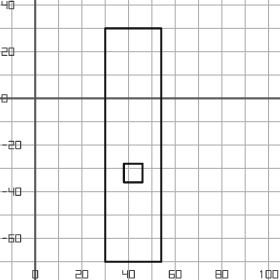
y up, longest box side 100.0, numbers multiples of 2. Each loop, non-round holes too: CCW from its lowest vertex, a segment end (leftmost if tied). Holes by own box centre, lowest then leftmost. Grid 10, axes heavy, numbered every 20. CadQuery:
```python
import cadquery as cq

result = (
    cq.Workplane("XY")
    .moveTo(30.0, -70.0)
    .lineTo(54.0, -70.0)
    .lineTo(54.0, 30.0)
    .lineTo(30.0, 30.0)
    .close()
    .moveTo(38.0, -36.0)
    .lineTo(46.0, -36.0)
    .lineTo(46.0, -28.0)
    .lineTo(38.0, -28.0)
    .close()
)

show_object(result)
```